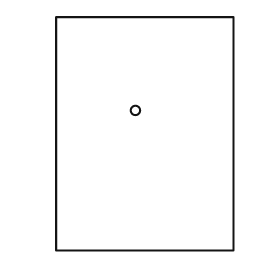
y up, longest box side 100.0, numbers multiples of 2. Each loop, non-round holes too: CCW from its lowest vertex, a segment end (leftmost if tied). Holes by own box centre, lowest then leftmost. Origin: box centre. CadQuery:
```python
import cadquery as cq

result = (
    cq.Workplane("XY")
    .moveTo(-38.0, -50.0)
    .lineTo(38.0, -50.0)
    .lineTo(38.0, 50.0)
    .lineTo(-38.0, 50.0)
    .close()
    .moveTo(-4.0, 10.0)
    .circle(2.0)
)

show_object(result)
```